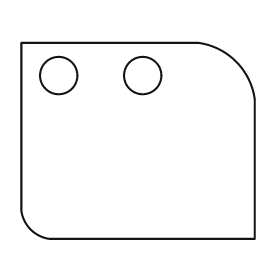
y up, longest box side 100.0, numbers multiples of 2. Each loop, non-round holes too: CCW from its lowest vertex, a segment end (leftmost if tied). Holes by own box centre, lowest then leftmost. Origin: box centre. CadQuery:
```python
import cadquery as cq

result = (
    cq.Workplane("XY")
    .moveTo(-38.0, -42.0)
    .lineTo(50.0, -42.0)
    .lineTo(50.0, 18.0)
    .threePointArc((42.0, 34.0), (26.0, 42.0))
    .lineTo(-50.0, 42.0)
    .lineTo(-50.0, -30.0)
    .threePointArc((-46.0, -38.0), (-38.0, -42.0))
    .close()
    .moveTo(-34.0, 28.0)
    .circle(8.0)
    .moveTo(2.0, 28.0)
    .circle(8.0)
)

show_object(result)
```